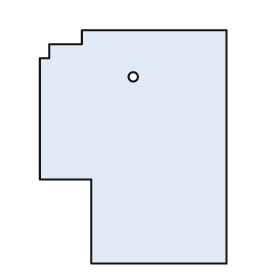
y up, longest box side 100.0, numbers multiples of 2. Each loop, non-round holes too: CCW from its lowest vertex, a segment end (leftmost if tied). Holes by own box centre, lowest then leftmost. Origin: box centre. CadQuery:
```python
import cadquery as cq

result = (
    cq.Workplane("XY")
    .moveTo(-18.0, -50.0)
    .lineTo(40.0, -50.0)
    .lineTo(40.0, 50.0)
    .lineTo(-22.0, 50.0)
    .lineTo(-22.0, 44.0)
    .lineTo(-36.0, 44.0)
    .lineTo(-36.0, 38.0)
    .lineTo(-40.0, 38.0)
    .lineTo(-40.0, -14.0)
    .lineTo(-18.0, -14.0)
    .close()
    .moveTo(0.0, 30.0)
    .circle(2.0)
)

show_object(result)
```